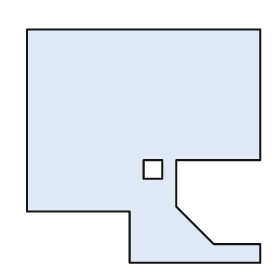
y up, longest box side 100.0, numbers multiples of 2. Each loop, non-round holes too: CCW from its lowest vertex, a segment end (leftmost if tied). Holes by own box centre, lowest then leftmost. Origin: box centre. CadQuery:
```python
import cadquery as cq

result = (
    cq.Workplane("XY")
    .moveTo(-6.0, -50.0)
    .lineTo(50.0, -50.0)
    .lineTo(50.0, -42.0)
    .lineTo(30.0, -42.0)
    .lineTo(14.0, -26.0)
    .lineTo(14.0, -6.0)
    .lineTo(50.0, -6.0)
    .lineTo(50.0, 50.0)
    .lineTo(-50.0, 50.0)
    .lineTo(-50.0, -28.0)
    .lineTo(-6.0, -28.0)
    .close()
    .moveTo(0.0, -14.0)
    .lineTo(8.0, -14.0)
    .lineTo(8.0, -6.0)
    .lineTo(0.0, -6.0)
    .close()
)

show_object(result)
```